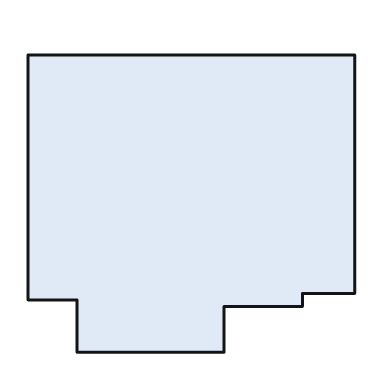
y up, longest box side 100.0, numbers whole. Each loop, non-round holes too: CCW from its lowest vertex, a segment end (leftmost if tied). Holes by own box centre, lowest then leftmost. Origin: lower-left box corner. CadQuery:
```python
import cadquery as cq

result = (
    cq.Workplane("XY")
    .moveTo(15.0, 0.0)
    .lineTo(60.0, 0.0)
    .lineTo(60.0, 14.0)
    .lineTo(84.0, 14.0)
    .lineTo(84.0, 18.0)
    .lineTo(100.0, 18.0)
    .lineTo(100.0, 91.0)
    .lineTo(0.0, 91.0)
    .lineTo(0.0, 16.0)
    .lineTo(15.0, 16.0)
    .close()
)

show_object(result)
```